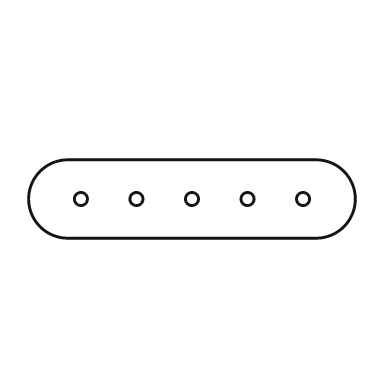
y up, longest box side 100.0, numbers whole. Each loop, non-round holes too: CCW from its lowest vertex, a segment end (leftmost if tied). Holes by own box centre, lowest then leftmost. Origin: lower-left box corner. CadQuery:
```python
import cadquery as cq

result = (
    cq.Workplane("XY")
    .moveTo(12.0, 0.0)
    .lineTo(88.0, 0.0)
    .threePointArc((100.0, 12.0), (88.0, 24.0))
    .lineTo(12.0, 24.0)
    .threePointArc((0.0, 12.0), (12.0, 0.0))
    .close()
    .moveTo(16.0, 12.0)
    .circle(2.0)
    .moveTo(33.0, 12.0)
    .circle(2.0)
    .moveTo(50.0, 12.0)
    .circle(2.0)
    .moveTo(67.0, 12.0)
    .circle(2.0)
    .moveTo(84.0, 12.0)
    .circle(2.0)
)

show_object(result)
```